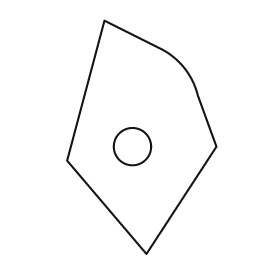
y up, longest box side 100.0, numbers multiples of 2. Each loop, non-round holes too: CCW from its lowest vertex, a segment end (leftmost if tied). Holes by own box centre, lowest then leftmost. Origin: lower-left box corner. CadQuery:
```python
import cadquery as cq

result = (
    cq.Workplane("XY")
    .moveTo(34.0, 0.0)
    .lineTo(64.0, 46.0)
    .lineTo(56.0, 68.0)
    .threePointArc((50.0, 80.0), (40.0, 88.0))
    .lineTo(16.0, 100.0)
    .lineTo(0.0, 40.0)
    .close()
    .moveTo(28.0, 46.0)
    .circle(8.0)
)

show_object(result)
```